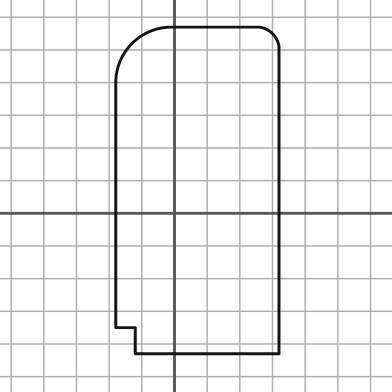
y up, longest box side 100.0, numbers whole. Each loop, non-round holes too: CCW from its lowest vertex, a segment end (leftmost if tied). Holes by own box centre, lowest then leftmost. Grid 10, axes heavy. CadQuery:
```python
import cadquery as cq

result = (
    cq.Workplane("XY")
    .moveTo(-12.0, -43.0)
    .lineTo(32.0, -43.0)
    .lineTo(32.0, 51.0)
    .threePointArc((30.0, 55.0), (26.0, 57.0))
    .lineTo(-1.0, 57.0)
    .threePointArc((-13.0, 52.0), (-18.0, 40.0))
    .lineTo(-18.0, -35.0)
    .lineTo(-12.0, -35.0)
    .close()
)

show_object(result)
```